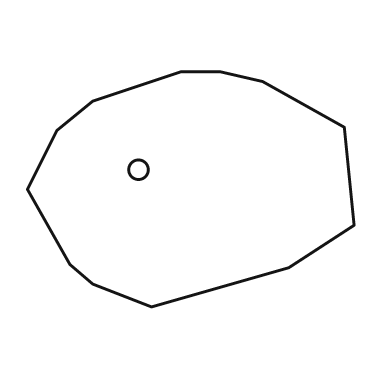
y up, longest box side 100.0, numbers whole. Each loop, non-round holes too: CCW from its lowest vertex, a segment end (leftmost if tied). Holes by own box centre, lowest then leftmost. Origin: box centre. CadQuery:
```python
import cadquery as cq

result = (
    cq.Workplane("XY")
    .moveTo(-12.0, -36.0)
    .lineTo(30.0, -24.0)
    .lineTo(50.0, -11.0)
    .lineTo(47.0, 19.0)
    .lineTo(22.0, 33.0)
    .lineTo(9.0, 36.0)
    .lineTo(-3.0, 36.0)
    .lineTo(-30.0, 27.0)
    .lineTo(-41.0, 18.0)
    .lineTo(-50.0, 0.0)
    .lineTo(-37.0, -23.0)
    .lineTo(-30.0, -29.0)
    .close()
    .moveTo(-16.0, 6.0)
    .circle(3.0)
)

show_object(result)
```